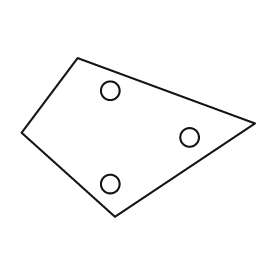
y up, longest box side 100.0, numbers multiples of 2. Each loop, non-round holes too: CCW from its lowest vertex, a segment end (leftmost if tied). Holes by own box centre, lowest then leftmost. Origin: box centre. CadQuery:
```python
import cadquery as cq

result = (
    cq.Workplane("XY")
    .moveTo(-10.0, -34.0)
    .lineTo(50.0, 6.0)
    .lineTo(-26.0, 34.0)
    .lineTo(-50.0, 2.0)
    .close()
    .moveTo(-12.0, -20.0)
    .circle(4.0)
    .moveTo(22.0, 0.0)
    .circle(4.0)
    .moveTo(-12.0, 20.0)
    .circle(4.0)
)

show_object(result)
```